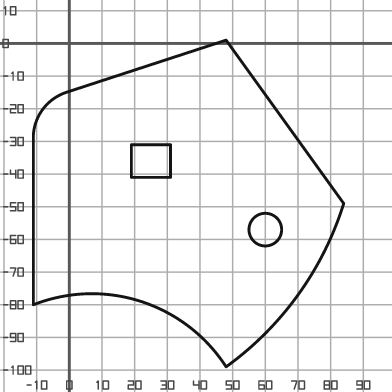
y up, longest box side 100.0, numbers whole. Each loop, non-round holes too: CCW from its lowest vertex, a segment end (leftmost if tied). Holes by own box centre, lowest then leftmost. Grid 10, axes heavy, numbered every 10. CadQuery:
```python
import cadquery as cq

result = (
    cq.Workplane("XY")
    .moveTo(48.0, -99.0)
    .threePointArc((70.0, -77.0), (84.0, -49.0))
    .lineTo(48.0, 1.0)
    .lineTo(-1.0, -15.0)
    .threePointArc((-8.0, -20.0), (-11.0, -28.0))
    .lineTo(-11.0, -80.0)
    .threePointArc((22.0, -79.0), (48.0, -99.0))
    .close()
    .moveTo(60.0, -57.0)
    .circle(5.0)
    .moveTo(19.0, -41.0)
    .lineTo(31.0, -41.0)
    .lineTo(31.0, -31.0)
    .lineTo(19.0, -31.0)
    .close()
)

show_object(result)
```